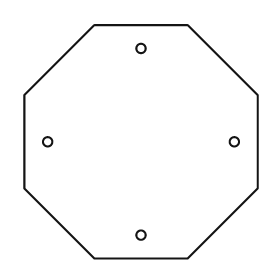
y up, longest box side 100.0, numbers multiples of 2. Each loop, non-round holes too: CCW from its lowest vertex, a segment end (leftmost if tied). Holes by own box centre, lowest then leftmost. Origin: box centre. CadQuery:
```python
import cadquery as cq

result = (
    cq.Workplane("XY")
    .moveTo(-20.0, -50.0)
    .lineTo(20.0, -50.0)
    .lineTo(50.0, -20.0)
    .lineTo(50.0, 20.0)
    .lineTo(20.0, 50.0)
    .lineTo(-20.0, 50.0)
    .lineTo(-50.0, 20.0)
    .lineTo(-50.0, -20.0)
    .close()
    .moveTo(0.0, -40.0)
    .circle(2.0)
    .moveTo(-40.0, 0.0)
    .circle(2.0)
    .moveTo(40.0, 0.0)
    .circle(2.0)
    .moveTo(0.0, 40.0)
    .circle(2.0)
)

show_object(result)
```